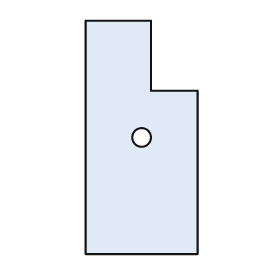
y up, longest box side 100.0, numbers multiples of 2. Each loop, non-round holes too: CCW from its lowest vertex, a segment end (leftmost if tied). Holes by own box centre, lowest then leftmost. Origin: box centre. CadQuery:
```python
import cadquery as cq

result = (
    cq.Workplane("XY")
    .moveTo(-24.0, -50.0)
    .lineTo(24.0, -50.0)
    .lineTo(24.0, 20.0)
    .lineTo(4.0, 20.0)
    .lineTo(4.0, 50.0)
    .lineTo(-24.0, 50.0)
    .close()
    .moveTo(0.0, 0.0)
    .circle(4.0)
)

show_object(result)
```